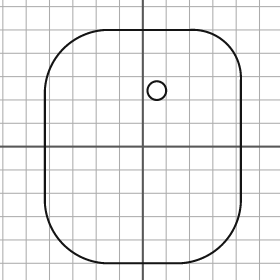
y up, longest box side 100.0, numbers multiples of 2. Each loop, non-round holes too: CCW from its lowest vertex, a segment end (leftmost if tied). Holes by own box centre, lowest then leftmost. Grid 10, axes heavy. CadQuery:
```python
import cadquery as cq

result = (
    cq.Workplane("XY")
    .moveTo(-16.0, -50.0)
    .lineTo(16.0, -50.0)
    .threePointArc((34.0, -42.0), (42.0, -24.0))
    .lineTo(42.0, 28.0)
    .threePointArc((36.0, 44.0), (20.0, 50.0))
    .lineTo(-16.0, 50.0)
    .threePointArc((-34.0, 42.0), (-42.0, 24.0))
    .lineTo(-42.0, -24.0)
    .threePointArc((-34.0, -42.0), (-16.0, -50.0))
    .close()
    .moveTo(6.0, 24.0)
    .circle(4.0)
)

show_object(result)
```